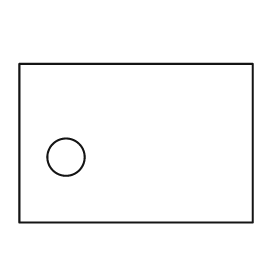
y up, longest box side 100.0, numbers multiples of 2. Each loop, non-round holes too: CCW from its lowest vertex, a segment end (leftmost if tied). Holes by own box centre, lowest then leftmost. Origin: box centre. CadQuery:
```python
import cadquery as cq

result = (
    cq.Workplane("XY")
    .moveTo(-50.0, -34.0)
    .lineTo(50.0, -34.0)
    .lineTo(50.0, 34.0)
    .lineTo(-50.0, 34.0)
    .close()
    .moveTo(-30.0, -6.0)
    .circle(8.0)
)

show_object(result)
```